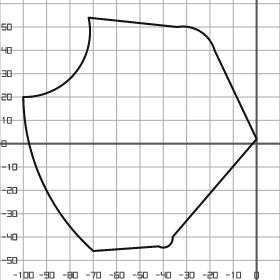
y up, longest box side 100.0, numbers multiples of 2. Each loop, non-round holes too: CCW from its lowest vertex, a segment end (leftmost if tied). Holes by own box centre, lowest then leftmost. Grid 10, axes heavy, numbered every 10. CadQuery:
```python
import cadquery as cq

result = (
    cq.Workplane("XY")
    .moveTo(-70.0, -46.0)
    .lineTo(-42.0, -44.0)
    .threePointArc((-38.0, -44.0), (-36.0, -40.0))
    .lineTo(0.0, 2.0)
    .lineTo(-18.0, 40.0)
    .threePointArc((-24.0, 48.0), (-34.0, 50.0))
    .lineTo(-72.0, 54.0)
    .threePointArc((-78.0, 30.0), (-100.0, 20.0))
    .threePointArc((-92.0, -16.0), (-70.0, -46.0))
    .close()
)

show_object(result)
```